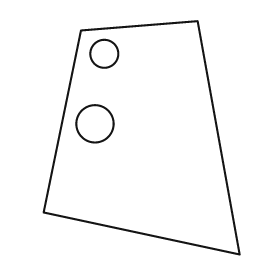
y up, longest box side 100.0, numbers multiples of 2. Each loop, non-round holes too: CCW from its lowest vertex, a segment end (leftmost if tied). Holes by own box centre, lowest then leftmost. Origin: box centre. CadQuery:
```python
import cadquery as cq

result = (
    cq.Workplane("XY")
    .moveTo(42.0, -50.0)
    .lineTo(24.0, 50.0)
    .lineTo(-26.0, 46.0)
    .lineTo(-42.0, -32.0)
    .close()
    .moveTo(-20.0, 6.0)
    .circle(8.0)
    .moveTo(-16.0, 36.0)
    .circle(6.0)
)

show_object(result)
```